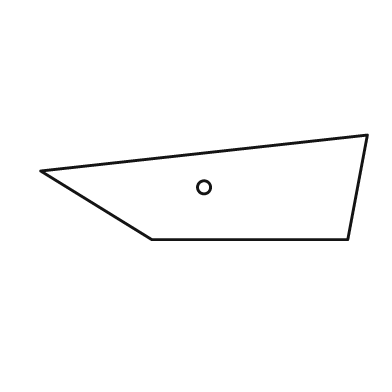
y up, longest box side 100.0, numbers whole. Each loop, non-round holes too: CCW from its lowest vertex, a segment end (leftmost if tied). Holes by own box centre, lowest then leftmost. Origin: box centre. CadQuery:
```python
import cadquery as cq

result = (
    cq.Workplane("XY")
    .moveTo(-16.0, -16.0)
    .lineTo(44.0, -16.0)
    .lineTo(50.0, 16.0)
    .lineTo(-50.0, 5.0)
    .close()
    .moveTo(0.0, 0.0)
    .circle(2.0)
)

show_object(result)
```